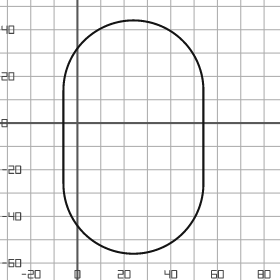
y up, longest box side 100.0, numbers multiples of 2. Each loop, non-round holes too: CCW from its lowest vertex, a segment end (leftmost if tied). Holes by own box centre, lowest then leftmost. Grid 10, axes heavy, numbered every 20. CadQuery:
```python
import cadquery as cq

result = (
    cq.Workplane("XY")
    .moveTo(-6.0, -26.0)
    .threePointArc((24.0, -56.0), (54.0, -26.0))
    .lineTo(54.0, 14.0)
    .threePointArc((24.0, 44.0), (-6.0, 14.0))
    .close()
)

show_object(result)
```